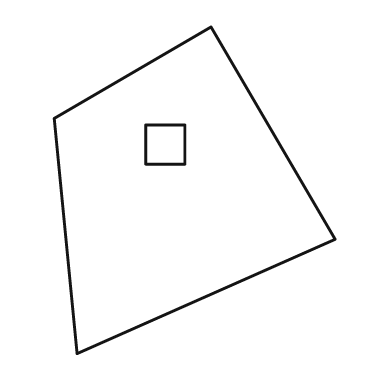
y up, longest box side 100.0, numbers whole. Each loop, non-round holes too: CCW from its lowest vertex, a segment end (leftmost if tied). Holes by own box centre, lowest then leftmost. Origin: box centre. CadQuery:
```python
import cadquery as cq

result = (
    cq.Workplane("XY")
    .moveTo(-36.0, -50.0)
    .lineTo(43.0, -15.0)
    .lineTo(5.0, 50.0)
    .lineTo(-43.0, 22.0)
    .close()
    .moveTo(-15.0, 8.0)
    .lineTo(-3.0, 8.0)
    .lineTo(-3.0, 20.0)
    .lineTo(-15.0, 20.0)
    .close()
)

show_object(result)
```